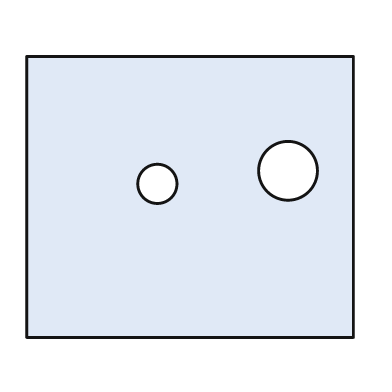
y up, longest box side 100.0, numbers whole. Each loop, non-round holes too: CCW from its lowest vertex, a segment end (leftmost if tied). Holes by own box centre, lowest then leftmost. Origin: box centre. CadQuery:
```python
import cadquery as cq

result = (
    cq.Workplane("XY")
    .moveTo(-50.0, -43.0)
    .lineTo(50.0, -43.0)
    .lineTo(50.0, 43.0)
    .lineTo(-50.0, 43.0)
    .close()
    .moveTo(-10.0, 4.0)
    .circle(6.0)
    .moveTo(30.0, 8.0)
    .circle(9.0)
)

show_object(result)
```